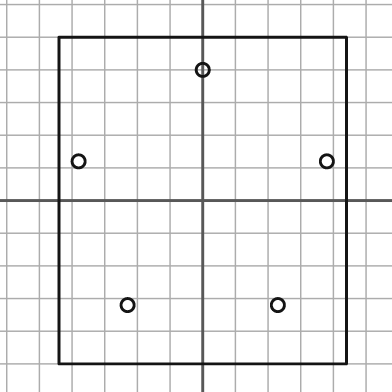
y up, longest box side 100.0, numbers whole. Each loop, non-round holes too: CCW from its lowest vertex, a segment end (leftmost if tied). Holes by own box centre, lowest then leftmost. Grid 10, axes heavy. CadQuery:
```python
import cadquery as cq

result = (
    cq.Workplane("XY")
    .moveTo(-44.0, -50.0)
    .lineTo(44.0, -50.0)
    .lineTo(44.0, 50.0)
    .lineTo(-44.0, 50.0)
    .close()
    .moveTo(-23.0, -32.0)
    .circle(2.0)
    .moveTo(23.0, -32.0)
    .circle(2.0)
    .moveTo(-38.0, 12.0)
    .circle(2.0)
    .moveTo(38.0, 12.0)
    .circle(2.0)
    .moveTo(0.0, 40.0)
    .circle(2.0)
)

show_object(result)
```